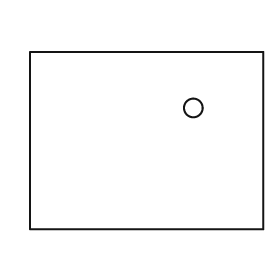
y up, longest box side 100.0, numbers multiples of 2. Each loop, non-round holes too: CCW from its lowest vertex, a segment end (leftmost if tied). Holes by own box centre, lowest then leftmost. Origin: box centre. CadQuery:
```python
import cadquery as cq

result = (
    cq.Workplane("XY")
    .moveTo(-50.0, -38.0)
    .lineTo(50.0, -38.0)
    .lineTo(50.0, 38.0)
    .lineTo(-50.0, 38.0)
    .close()
    .moveTo(20.0, 14.0)
    .circle(4.0)
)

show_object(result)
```